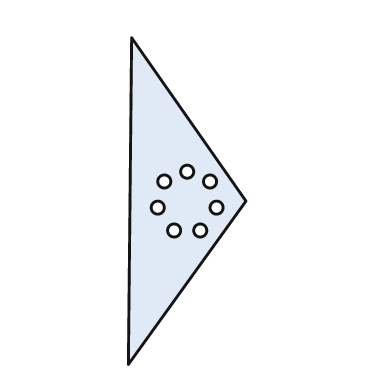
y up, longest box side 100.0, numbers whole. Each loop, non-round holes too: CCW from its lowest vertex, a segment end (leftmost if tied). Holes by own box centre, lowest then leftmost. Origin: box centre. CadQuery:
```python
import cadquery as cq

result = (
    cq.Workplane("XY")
    .moveTo(-18.0, -50.0)
    .lineTo(18.0, 0.0)
    .lineTo(-17.0, 50.0)
    .close()
    .moveTo(-4.0, -9.0)
    .circle(2.0)
    .moveTo(4.0, -9.0)
    .circle(2.0)
    .moveTo(-9.0, -2.0)
    .circle(2.0)
    .moveTo(9.0, -2.0)
    .circle(2.0)
    .moveTo(-7.0, 6.0)
    .circle(2.0)
    .moveTo(7.0, 6.0)
    .circle(2.0)
    .moveTo(0.0, 9.0)
    .circle(2.0)
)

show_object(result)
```